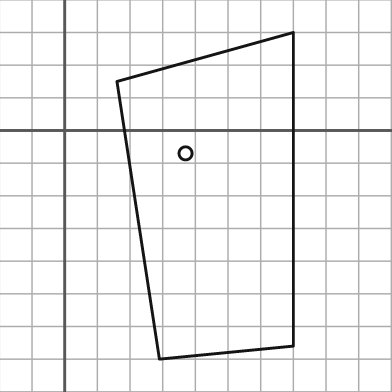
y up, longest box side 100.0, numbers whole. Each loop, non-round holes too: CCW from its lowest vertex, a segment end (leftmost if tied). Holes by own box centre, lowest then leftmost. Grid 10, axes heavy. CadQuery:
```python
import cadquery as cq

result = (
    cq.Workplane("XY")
    .moveTo(29.0, -70.0)
    .lineTo(70.0, -66.0)
    .lineTo(70.0, 30.0)
    .lineTo(16.0, 15.0)
    .close()
    .moveTo(37.0, -7.0)
    .circle(2.0)
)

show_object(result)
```